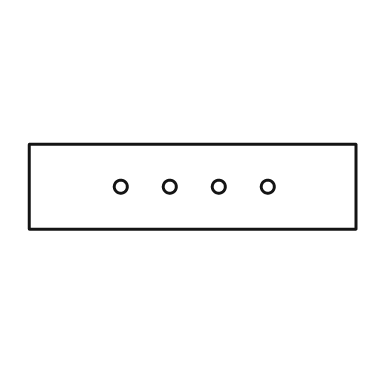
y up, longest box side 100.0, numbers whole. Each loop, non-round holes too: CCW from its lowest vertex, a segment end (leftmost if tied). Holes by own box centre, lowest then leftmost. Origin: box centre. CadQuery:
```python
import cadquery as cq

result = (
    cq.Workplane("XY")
    .moveTo(-50.0, -13.0)
    .lineTo(50.0, -13.0)
    .lineTo(50.0, 13.0)
    .lineTo(-50.0, 13.0)
    .close()
    .moveTo(-22.0, 0.0)
    .circle(2.0)
    .moveTo(-7.0, 0.0)
    .circle(2.0)
    .moveTo(8.0, 0.0)
    .circle(2.0)
    .moveTo(23.0, 0.0)
    .circle(2.0)
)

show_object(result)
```